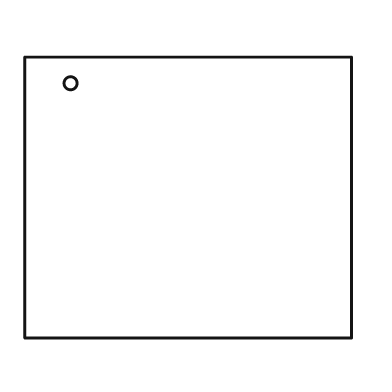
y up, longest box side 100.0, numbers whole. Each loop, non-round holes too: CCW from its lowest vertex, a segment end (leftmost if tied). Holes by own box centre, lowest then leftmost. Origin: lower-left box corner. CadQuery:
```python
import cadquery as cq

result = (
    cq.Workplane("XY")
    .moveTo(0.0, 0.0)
    .lineTo(100.0, 0.0)
    .lineTo(100.0, 86.0)
    .lineTo(0.0, 86.0)
    .close()
    .moveTo(14.0, 78.0)
    .circle(2.0)
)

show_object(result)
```